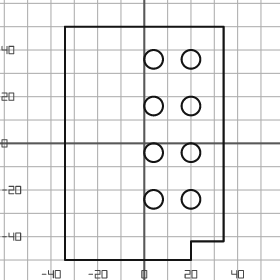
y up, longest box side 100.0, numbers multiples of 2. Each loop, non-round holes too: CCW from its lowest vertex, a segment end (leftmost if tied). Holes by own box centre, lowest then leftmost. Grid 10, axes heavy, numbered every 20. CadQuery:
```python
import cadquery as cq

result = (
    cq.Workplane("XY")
    .moveTo(-34.0, -50.0)
    .lineTo(20.0, -50.0)
    .lineTo(20.0, -42.0)
    .lineTo(34.0, -42.0)
    .lineTo(34.0, 50.0)
    .lineTo(-34.0, 50.0)
    .close()
    .moveTo(4.0, -24.0)
    .circle(4.0)
    .moveTo(20.0, -24.0)
    .circle(4.0)
    .moveTo(4.0, -4.0)
    .circle(4.0)
    .moveTo(20.0, -4.0)
    .circle(4.0)
    .moveTo(4.0, 16.0)
    .circle(4.0)
    .moveTo(20.0, 16.0)
    .circle(4.0)
    .moveTo(4.0, 36.0)
    .circle(4.0)
    .moveTo(20.0, 36.0)
    .circle(4.0)
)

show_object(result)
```